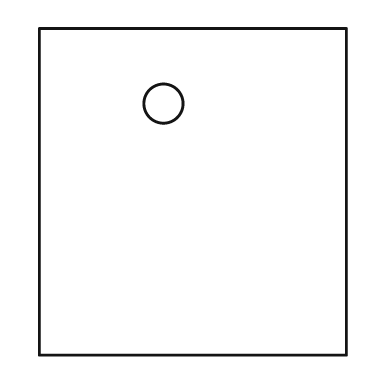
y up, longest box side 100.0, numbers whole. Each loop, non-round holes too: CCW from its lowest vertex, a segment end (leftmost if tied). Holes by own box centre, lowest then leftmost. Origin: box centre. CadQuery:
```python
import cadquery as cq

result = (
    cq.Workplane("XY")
    .moveTo(-47.0, -50.0)
    .lineTo(47.0, -50.0)
    .lineTo(47.0, 50.0)
    .lineTo(-47.0, 50.0)
    .close()
    .moveTo(-9.0, 27.0)
    .circle(6.0)
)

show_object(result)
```